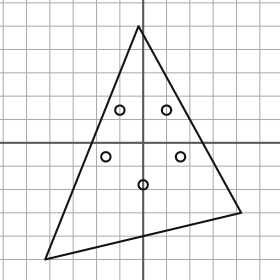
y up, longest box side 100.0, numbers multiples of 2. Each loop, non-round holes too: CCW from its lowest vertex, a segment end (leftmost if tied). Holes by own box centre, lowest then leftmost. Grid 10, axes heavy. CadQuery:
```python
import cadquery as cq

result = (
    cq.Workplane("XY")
    .moveTo(-42.0, -50.0)
    .lineTo(42.0, -30.0)
    .lineTo(-2.0, 50.0)
    .close()
    .moveTo(0.0, -18.0)
    .circle(2.0)
    .moveTo(-16.0, -6.0)
    .circle(2.0)
    .moveTo(16.0, -6.0)
    .circle(2.0)
    .moveTo(-10.0, 14.0)
    .circle(2.0)
    .moveTo(10.0, 14.0)
    .circle(2.0)
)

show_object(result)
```